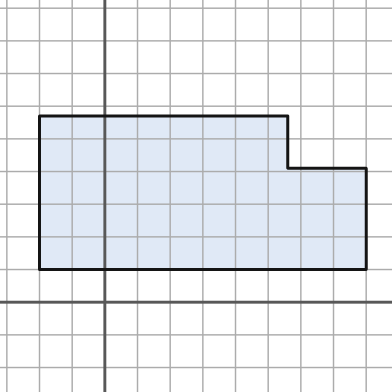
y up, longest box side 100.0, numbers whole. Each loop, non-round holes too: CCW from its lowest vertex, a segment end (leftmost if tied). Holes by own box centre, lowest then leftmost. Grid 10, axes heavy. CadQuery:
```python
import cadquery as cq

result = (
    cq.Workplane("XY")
    .moveTo(-20.0, 10.0)
    .lineTo(80.0, 10.0)
    .lineTo(80.0, 41.0)
    .lineTo(56.0, 41.0)
    .lineTo(56.0, 57.0)
    .lineTo(-20.0, 57.0)
    .close()
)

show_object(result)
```